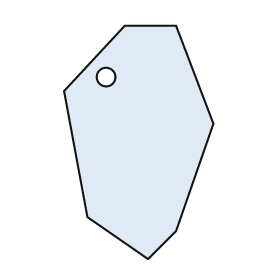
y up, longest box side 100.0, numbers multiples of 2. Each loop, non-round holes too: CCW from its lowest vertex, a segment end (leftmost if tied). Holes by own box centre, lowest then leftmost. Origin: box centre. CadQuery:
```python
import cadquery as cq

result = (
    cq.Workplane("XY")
    .moveTo(4.0, -50.0)
    .lineTo(16.0, -38.0)
    .lineTo(32.0, 8.0)
    .lineTo(16.0, 50.0)
    .lineTo(-6.0, 50.0)
    .lineTo(-32.0, 22.0)
    .lineTo(-22.0, -32.0)
    .close()
    .moveTo(-14.0, 28.0)
    .circle(4.0)
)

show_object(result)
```